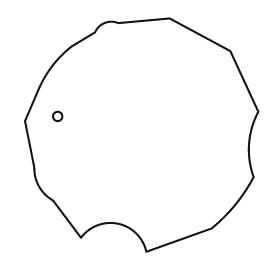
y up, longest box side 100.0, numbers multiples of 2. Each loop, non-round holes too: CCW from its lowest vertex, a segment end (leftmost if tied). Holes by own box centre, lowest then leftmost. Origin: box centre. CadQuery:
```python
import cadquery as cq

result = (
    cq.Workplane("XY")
    .moveTo(2.0, -50.0)
    .lineTo(30.0, -40.0)
    .threePointArc((40.0, -30.0), (48.0, -18.0))
    .threePointArc((46.0, -4.0), (50.0, 10.0))
    .lineTo(38.0, 36.0)
    .lineTo(12.0, 50.0)
    .lineTo(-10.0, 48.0)
    .threePointArc((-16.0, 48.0), (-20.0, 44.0))
    .lineTo(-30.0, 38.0)
    .threePointArc((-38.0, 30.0), (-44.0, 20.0))
    .lineTo(-50.0, 6.0)
    .lineTo(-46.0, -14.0)
    .threePointArc((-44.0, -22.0), (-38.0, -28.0))
    .lineTo(-26.0, -44.0)
    .threePointArc((-10.0, -38.0), (2.0, -50.0))
    .close()
    .moveTo(-36.0, 8.0)
    .circle(2.0)
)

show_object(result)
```